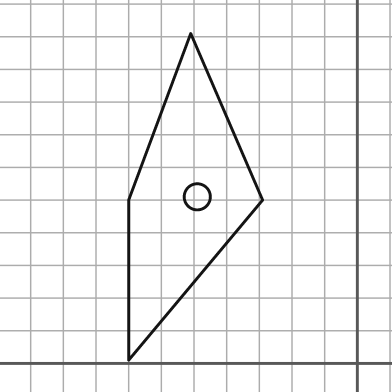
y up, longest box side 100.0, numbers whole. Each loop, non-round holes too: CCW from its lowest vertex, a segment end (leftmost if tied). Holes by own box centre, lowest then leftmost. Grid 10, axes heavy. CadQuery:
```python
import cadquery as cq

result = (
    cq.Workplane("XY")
    .moveTo(-70.0, 1.0)
    .lineTo(-29.0, 50.0)
    .lineTo(-51.0, 101.0)
    .lineTo(-70.0, 50.0)
    .close()
    .moveTo(-49.0, 51.0)
    .circle(4.0)
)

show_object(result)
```